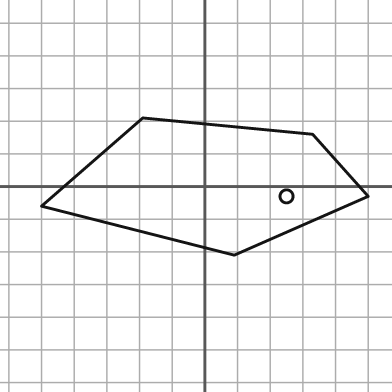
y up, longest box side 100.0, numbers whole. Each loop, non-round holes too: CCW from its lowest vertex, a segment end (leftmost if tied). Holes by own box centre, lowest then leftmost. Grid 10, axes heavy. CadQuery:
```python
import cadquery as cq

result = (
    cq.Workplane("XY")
    .moveTo(9.0, -21.0)
    .lineTo(50.0, -3.0)
    .lineTo(33.0, 16.0)
    .lineTo(-19.0, 21.0)
    .lineTo(-50.0, -6.0)
    .close()
    .moveTo(25.0, -3.0)
    .circle(2.0)
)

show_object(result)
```